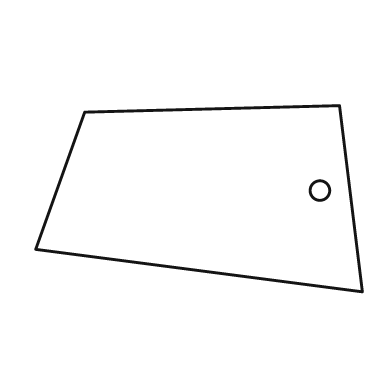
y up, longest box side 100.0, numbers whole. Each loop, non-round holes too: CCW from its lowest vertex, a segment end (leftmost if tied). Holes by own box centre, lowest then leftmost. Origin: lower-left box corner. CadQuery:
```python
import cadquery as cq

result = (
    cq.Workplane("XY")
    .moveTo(100.0, 0.0)
    .lineTo(93.0, 57.0)
    .lineTo(15.0, 55.0)
    .lineTo(0.0, 13.0)
    .close()
    .moveTo(87.0, 31.0)
    .circle(3.0)
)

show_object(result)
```